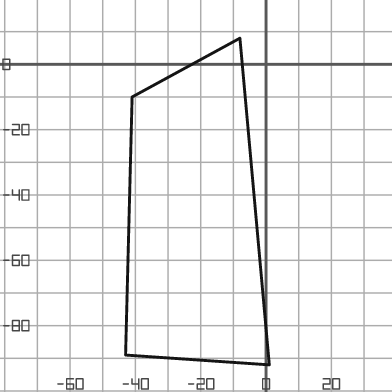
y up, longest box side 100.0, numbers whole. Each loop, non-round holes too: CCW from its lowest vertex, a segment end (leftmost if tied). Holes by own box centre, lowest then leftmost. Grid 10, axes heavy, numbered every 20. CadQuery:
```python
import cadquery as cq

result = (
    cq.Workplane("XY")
    .moveTo(1.0, -92.0)
    .lineTo(-8.0, 8.0)
    .lineTo(-41.0, -10.0)
    .lineTo(-43.0, -89.0)
    .close()
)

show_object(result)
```